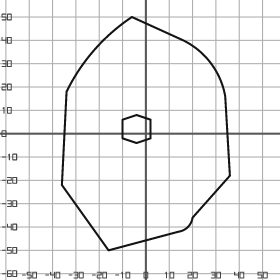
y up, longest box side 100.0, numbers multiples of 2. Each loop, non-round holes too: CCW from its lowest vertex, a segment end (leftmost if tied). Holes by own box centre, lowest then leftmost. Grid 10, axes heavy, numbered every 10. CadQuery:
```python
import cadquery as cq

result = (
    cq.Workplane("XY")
    .moveTo(-16.0, -50.0)
    .lineTo(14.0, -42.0)
    .threePointArc((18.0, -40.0), (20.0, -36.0))
    .lineTo(36.0, -18.0)
    .lineTo(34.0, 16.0)
    .threePointArc((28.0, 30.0), (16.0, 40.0))
    .lineTo(-6.0, 50.0)
    .threePointArc((-22.0, 36.0), (-34.0, 18.0))
    .lineTo(-36.0, -22.0)
    .close()
    .moveTo(-4.0, -4.0)
    .lineTo(2.0, -2.0)
    .lineTo(2.0, 6.0)
    .lineTo(-4.0, 8.0)
    .lineTo(-10.0, 6.0)
    .lineTo(-10.0, -2.0)
    .close()
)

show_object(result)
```